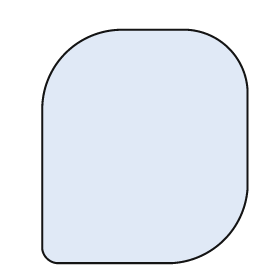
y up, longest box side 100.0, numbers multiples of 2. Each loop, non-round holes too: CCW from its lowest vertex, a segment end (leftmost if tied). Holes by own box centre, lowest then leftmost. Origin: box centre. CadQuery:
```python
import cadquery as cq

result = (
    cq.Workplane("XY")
    .moveTo(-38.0, -50.0)
    .lineTo(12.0, -50.0)
    .threePointArc((34.0, -40.0), (44.0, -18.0))
    .lineTo(44.0, 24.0)
    .threePointArc((36.0, 42.0), (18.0, 50.0))
    .lineTo(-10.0, 50.0)
    .threePointArc((-34.0, 40.0), (-44.0, 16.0))
    .lineTo(-44.0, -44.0)
    .threePointArc((-42.0, -48.0), (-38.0, -50.0))
    .close()
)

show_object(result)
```